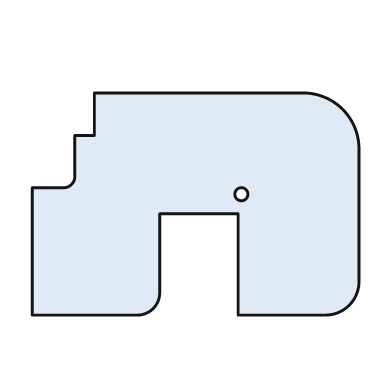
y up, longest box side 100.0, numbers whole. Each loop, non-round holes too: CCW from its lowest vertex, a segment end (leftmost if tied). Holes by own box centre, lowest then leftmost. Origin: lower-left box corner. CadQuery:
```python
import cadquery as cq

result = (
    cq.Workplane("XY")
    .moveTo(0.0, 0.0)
    .lineTo(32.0, 0.0)
    .threePointArc((37.0, 2.0), (39.0, 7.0))
    .lineTo(39.0, 31.0)
    .lineTo(63.0, 31.0)
    .lineTo(63.0, 0.0)
    .lineTo(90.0, 0.0)
    .threePointArc((97.0, 3.0), (100.0, 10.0))
    .lineTo(100.0, 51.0)
    .threePointArc((95.0, 63.0), (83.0, 68.0))
    .lineTo(19.0, 68.0)
    .lineTo(19.0, 55.0)
    .lineTo(13.0, 55.0)
    .lineTo(13.0, 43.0)
    .threePointArc((12.0, 40.0), (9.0, 39.0))
    .lineTo(0.0, 39.0)
    .close()
    .moveTo(64.0, 37.0)
    .circle(2.0)
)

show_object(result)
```